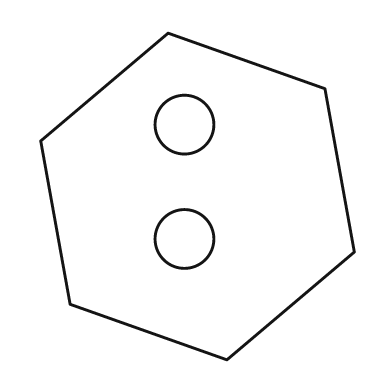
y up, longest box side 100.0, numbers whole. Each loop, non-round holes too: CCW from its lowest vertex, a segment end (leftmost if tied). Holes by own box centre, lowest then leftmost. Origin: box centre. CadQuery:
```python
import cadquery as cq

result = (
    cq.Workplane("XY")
    .moveTo(9.0, -50.0)
    .lineTo(48.0, -17.0)
    .lineTo(39.0, 33.0)
    .lineTo(-9.0, 50.0)
    .lineTo(-48.0, 17.0)
    .lineTo(-39.0, -33.0)
    .close()
    .moveTo(-4.0, -13.0)
    .circle(9.0)
    .moveTo(-4.0, 22.0)
    .circle(9.0)
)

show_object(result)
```